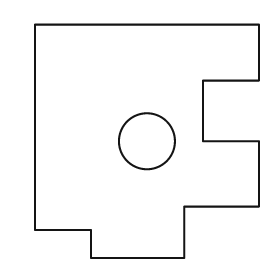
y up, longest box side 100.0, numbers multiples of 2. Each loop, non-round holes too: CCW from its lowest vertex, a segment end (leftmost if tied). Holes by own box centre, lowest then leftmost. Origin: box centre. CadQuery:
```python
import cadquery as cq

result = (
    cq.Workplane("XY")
    .moveTo(-24.0, -50.0)
    .lineTo(16.0, -50.0)
    .lineTo(16.0, -28.0)
    .lineTo(48.0, -28.0)
    .lineTo(48.0, 0.0)
    .lineTo(24.0, 0.0)
    .lineTo(24.0, 26.0)
    .lineTo(48.0, 26.0)
    .lineTo(48.0, 50.0)
    .lineTo(-48.0, 50.0)
    .lineTo(-48.0, -38.0)
    .lineTo(-24.0, -38.0)
    .close()
    .moveTo(0.0, 0.0)
    .circle(12.0)
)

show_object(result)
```